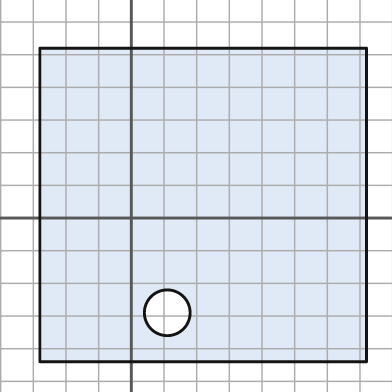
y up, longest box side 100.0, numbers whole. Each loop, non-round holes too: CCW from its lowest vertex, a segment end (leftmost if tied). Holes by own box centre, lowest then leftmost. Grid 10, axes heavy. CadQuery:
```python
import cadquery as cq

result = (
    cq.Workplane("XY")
    .moveTo(-28.0, -44.0)
    .lineTo(72.0, -44.0)
    .lineTo(72.0, 52.0)
    .lineTo(-28.0, 52.0)
    .close()
    .moveTo(11.0, -29.0)
    .circle(7.0)
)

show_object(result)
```